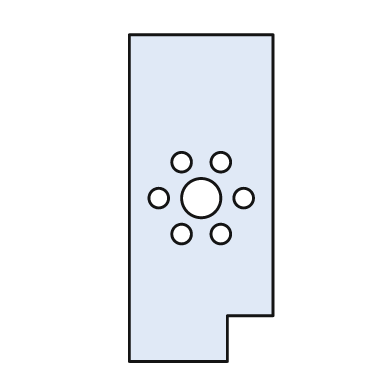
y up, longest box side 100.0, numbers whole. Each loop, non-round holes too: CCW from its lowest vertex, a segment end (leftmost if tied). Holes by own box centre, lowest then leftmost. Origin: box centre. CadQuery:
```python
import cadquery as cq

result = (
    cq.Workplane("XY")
    .moveTo(-22.0, -50.0)
    .lineTo(8.0, -50.0)
    .lineTo(8.0, -36.0)
    .lineTo(22.0, -36.0)
    .lineTo(22.0, 50.0)
    .lineTo(-22.0, 50.0)
    .close()
    .moveTo(-6.0, -11.0)
    .circle(3.0)
    .moveTo(6.0, -11.0)
    .circle(3.0)
    .moveTo(-13.0, 0.0)
    .circle(3.0)
    .moveTo(0.0, 0.0)
    .circle(6.0)
    .moveTo(13.0, 0.0)
    .circle(3.0)
    .moveTo(-6.0, 11.0)
    .circle(3.0)
    .moveTo(6.0, 11.0)
    .circle(3.0)
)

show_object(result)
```